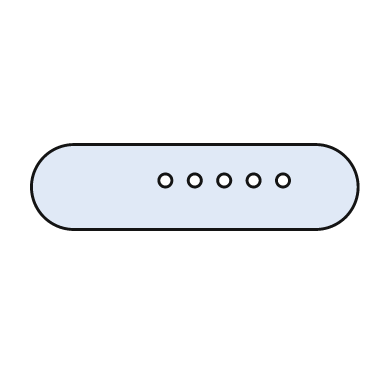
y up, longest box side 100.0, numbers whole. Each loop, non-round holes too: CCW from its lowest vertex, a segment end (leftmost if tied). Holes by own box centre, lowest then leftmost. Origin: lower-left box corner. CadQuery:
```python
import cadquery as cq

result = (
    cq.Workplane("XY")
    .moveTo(13.0, 0.0)
    .lineTo(87.0, 0.0)
    .threePointArc((100.0, 13.0), (87.0, 26.0))
    .lineTo(13.0, 26.0)
    .threePointArc((0.0, 13.0), (13.0, 0.0))
    .close()
    .moveTo(41.0, 15.0)
    .circle(2.0)
    .moveTo(50.0, 15.0)
    .circle(2.0)
    .moveTo(59.0, 15.0)
    .circle(2.0)
    .moveTo(68.0, 15.0)
    .circle(2.0)
    .moveTo(77.0, 15.0)
    .circle(2.0)
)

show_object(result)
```